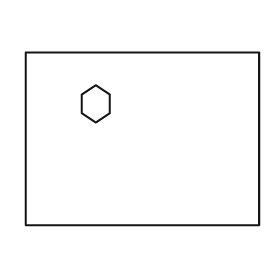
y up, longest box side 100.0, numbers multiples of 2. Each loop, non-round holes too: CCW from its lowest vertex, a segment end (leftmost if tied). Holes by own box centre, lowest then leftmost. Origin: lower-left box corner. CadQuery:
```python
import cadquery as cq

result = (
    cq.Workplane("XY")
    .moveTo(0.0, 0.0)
    .lineTo(100.0, 0.0)
    .lineTo(100.0, 74.0)
    .lineTo(0.0, 74.0)
    .close()
    .moveTo(30.0, 44.0)
    .lineTo(36.0, 48.0)
    .lineTo(36.0, 56.0)
    .lineTo(30.0, 60.0)
    .lineTo(24.0, 56.0)
    .lineTo(24.0, 48.0)
    .close()
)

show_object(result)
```